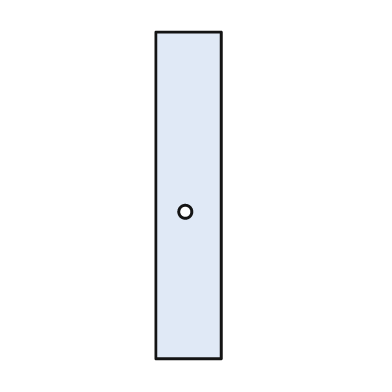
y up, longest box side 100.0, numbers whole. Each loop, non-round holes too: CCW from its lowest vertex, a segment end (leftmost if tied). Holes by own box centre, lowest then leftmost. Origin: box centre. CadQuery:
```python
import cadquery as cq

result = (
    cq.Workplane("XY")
    .moveTo(-10.0, -50.0)
    .lineTo(10.0, -50.0)
    .lineTo(10.0, 50.0)
    .lineTo(-10.0, 50.0)
    .close()
    .moveTo(-1.0, -5.0)
    .circle(2.0)
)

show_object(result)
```